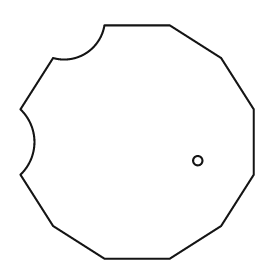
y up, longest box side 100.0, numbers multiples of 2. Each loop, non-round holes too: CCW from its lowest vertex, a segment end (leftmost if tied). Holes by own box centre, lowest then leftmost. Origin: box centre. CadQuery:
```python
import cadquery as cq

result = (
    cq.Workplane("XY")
    .moveTo(-14.0, -50.0)
    .lineTo(14.0, -50.0)
    .lineTo(36.0, -36.0)
    .lineTo(50.0, -14.0)
    .lineTo(50.0, 14.0)
    .lineTo(36.0, 36.0)
    .lineTo(14.0, 50.0)
    .lineTo(-14.0, 50.0)
    .threePointArc((-22.0, 38.0), (-36.0, 36.0))
    .lineTo(-50.0, 14.0)
    .threePointArc((-44.0, 0.0), (-50.0, -14.0))
    .lineTo(-36.0, -36.0)
    .close()
    .moveTo(26.0, -8.0)
    .circle(2.0)
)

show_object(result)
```